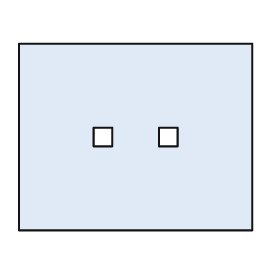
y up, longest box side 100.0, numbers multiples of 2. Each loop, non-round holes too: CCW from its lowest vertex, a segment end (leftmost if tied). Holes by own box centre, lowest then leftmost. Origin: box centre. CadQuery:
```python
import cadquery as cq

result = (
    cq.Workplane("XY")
    .moveTo(-50.0, -40.0)
    .lineTo(50.0, -40.0)
    .lineTo(50.0, 40.0)
    .lineTo(-50.0, 40.0)
    .close()
    .moveTo(-18.0, -4.0)
    .lineTo(-10.0, -4.0)
    .lineTo(-10.0, 4.0)
    .lineTo(-18.0, 4.0)
    .close()
    .moveTo(10.0, -4.0)
    .lineTo(18.0, -4.0)
    .lineTo(18.0, 4.0)
    .lineTo(10.0, 4.0)
    .close()
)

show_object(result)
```